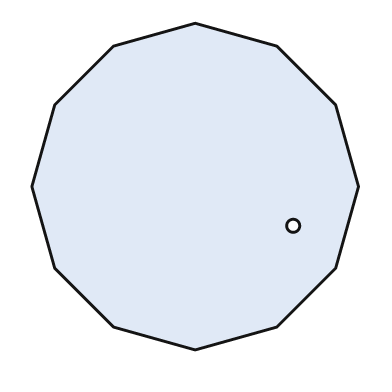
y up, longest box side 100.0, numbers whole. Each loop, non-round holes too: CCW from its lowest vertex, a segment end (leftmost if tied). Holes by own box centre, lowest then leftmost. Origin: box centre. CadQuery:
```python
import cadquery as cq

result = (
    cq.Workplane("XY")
    .moveTo(0.0, -50.0)
    .lineTo(25.0, -43.0)
    .lineTo(43.0, -25.0)
    .lineTo(50.0, 0.0)
    .lineTo(43.0, 25.0)
    .lineTo(25.0, 43.0)
    .lineTo(0.0, 50.0)
    .lineTo(-25.0, 43.0)
    .lineTo(-43.0, 25.0)
    .lineTo(-50.0, 0.0)
    .lineTo(-43.0, -25.0)
    .lineTo(-25.0, -43.0)
    .close()
    .moveTo(30.0, -12.0)
    .circle(2.0)
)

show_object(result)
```